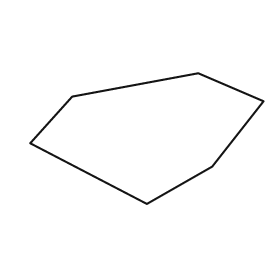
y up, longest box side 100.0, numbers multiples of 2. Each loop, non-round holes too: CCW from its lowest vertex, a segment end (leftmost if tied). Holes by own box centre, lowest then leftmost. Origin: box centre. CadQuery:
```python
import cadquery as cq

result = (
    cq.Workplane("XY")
    .moveTo(0.0, -28.0)
    .lineTo(28.0, -12.0)
    .lineTo(50.0, 16.0)
    .lineTo(22.0, 28.0)
    .lineTo(-32.0, 18.0)
    .lineTo(-50.0, -2.0)
    .close()
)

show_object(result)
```